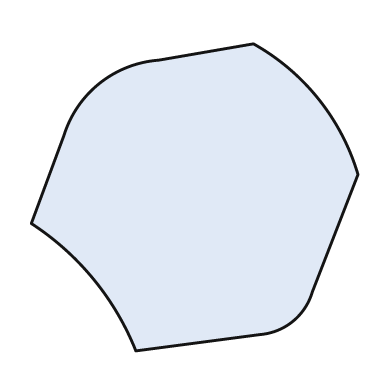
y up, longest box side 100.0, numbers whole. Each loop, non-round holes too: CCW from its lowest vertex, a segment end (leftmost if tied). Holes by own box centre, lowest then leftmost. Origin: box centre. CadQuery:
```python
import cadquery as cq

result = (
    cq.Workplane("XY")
    .moveTo(-18.0, -47.0)
    .lineTo(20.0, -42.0)
    .threePointArc((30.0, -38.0), (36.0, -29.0))
    .lineTo(50.0, 7.0)
    .threePointArc((38.0, 30.0), (18.0, 47.0))
    .lineTo(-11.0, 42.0)
    .threePointArc((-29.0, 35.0), (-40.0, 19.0))
    .lineTo(-50.0, -8.0)
    .threePointArc((-31.0, -25.0), (-18.0, -47.0))
    .close()
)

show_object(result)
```